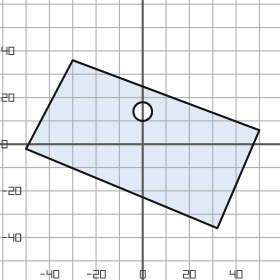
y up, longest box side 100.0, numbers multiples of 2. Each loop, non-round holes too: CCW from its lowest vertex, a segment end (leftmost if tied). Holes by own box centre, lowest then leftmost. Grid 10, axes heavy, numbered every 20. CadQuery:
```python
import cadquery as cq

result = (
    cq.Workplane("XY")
    .moveTo(32.0, -36.0)
    .lineTo(50.0, 6.0)
    .lineTo(-30.0, 36.0)
    .lineTo(-50.0, -2.0)
    .close()
    .moveTo(0.0, 14.0)
    .circle(4.0)
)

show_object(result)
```